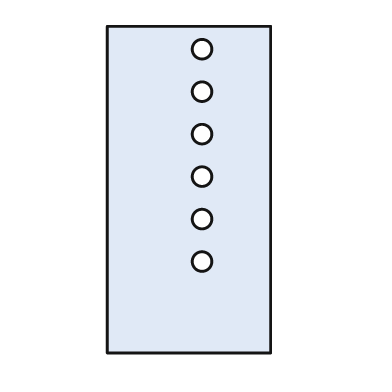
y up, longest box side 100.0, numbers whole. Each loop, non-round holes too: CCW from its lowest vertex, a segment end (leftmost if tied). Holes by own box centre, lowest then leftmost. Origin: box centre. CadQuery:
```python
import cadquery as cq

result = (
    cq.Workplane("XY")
    .moveTo(-25.0, -50.0)
    .lineTo(25.0, -50.0)
    .lineTo(25.0, 50.0)
    .lineTo(-25.0, 50.0)
    .close()
    .moveTo(4.0, -22.0)
    .circle(3.0)
    .moveTo(4.0, -9.0)
    .circle(3.0)
    .moveTo(4.0, 4.0)
    .circle(3.0)
    .moveTo(4.0, 17.0)
    .circle(3.0)
    .moveTo(4.0, 30.0)
    .circle(3.0)
    .moveTo(4.0, 43.0)
    .circle(3.0)
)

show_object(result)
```